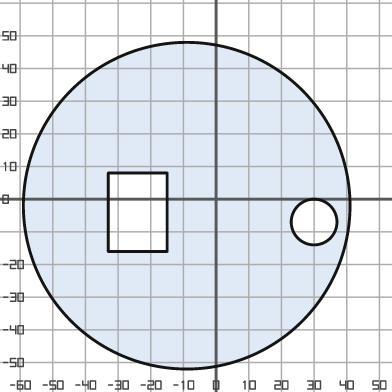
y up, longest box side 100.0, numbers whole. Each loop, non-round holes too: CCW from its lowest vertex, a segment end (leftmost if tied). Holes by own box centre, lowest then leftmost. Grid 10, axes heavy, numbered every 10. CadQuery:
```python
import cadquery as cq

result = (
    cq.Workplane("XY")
    .moveTo(-9.0, -2.0)
    .circle(50.0)
    .moveTo(30.0, -7.0)
    .circle(7.0)
    .moveTo(-33.0, -16.0)
    .lineTo(-15.0, -16.0)
    .lineTo(-15.0, 8.0)
    .lineTo(-33.0, 8.0)
    .close()
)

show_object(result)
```